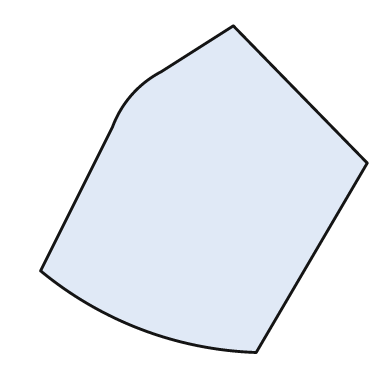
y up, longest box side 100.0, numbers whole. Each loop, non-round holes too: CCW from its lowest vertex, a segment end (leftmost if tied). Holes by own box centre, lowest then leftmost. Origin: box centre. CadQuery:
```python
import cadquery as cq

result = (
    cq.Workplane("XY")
    .moveTo(16.0, -50.0)
    .lineTo(50.0, 8.0)
    .lineTo(9.0, 50.0)
    .lineTo(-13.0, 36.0)
    .threePointArc((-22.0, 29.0), (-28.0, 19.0))
    .lineTo(-50.0, -25.0)
    .threePointArc((-19.0, -43.0), (16.0, -50.0))
    .close()
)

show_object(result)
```